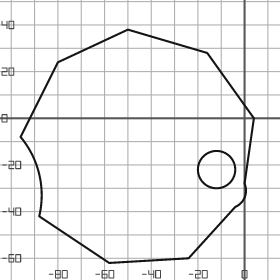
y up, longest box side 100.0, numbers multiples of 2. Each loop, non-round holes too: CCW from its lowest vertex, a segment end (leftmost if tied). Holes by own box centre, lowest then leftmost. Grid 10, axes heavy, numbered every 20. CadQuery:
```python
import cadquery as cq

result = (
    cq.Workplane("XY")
    .moveTo(-58.0, -62.0)
    .lineTo(-24.0, -60.0)
    .lineTo(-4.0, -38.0)
    .threePointArc((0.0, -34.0), (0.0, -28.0))
    .lineTo(4.0, 0.0)
    .lineTo(-16.0, 28.0)
    .lineTo(-50.0, 38.0)
    .lineTo(-80.0, 24.0)
    .lineTo(-96.0, -8.0)
    .threePointArc((-88.0, -24.0), (-88.0, -42.0))
    .close()
    .moveTo(-12.0, -22.0)
    .circle(8.0)
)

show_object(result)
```